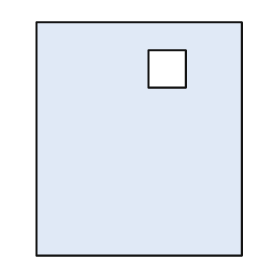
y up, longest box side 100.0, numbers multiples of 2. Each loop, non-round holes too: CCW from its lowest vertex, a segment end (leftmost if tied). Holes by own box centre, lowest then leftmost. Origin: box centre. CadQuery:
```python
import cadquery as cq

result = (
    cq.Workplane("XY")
    .moveTo(-44.0, -50.0)
    .lineTo(44.0, -50.0)
    .lineTo(44.0, 50.0)
    .lineTo(-44.0, 50.0)
    .close()
    .moveTo(4.0, 22.0)
    .lineTo(20.0, 22.0)
    .lineTo(20.0, 38.0)
    .lineTo(4.0, 38.0)
    .close()
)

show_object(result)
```